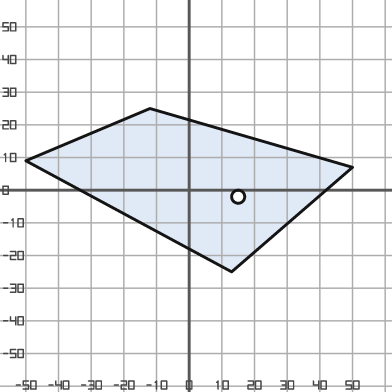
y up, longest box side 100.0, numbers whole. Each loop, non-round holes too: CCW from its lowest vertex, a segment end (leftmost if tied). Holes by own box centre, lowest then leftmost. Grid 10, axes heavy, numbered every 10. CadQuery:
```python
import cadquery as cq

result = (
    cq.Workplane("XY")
    .moveTo(13.0, -25.0)
    .lineTo(50.0, 7.0)
    .lineTo(-12.0, 25.0)
    .lineTo(-50.0, 9.0)
    .close()
    .moveTo(15.0, -2.0)
    .circle(2.0)
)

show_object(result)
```